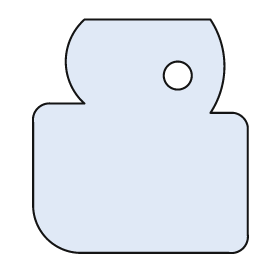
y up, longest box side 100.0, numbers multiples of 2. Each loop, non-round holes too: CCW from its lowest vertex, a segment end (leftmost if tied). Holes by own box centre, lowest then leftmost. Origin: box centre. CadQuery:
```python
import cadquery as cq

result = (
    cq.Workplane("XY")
    .moveTo(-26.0, -50.0)
    .lineTo(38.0, -50.0)
    .threePointArc((44.0, -48.0), (46.0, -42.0))
    .lineTo(46.0, 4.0)
    .threePointArc((44.0, 8.0), (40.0, 10.0))
    .lineTo(30.0, 10.0)
    .threePointArc((36.0, 30.0), (30.0, 50.0))
    .lineTo(-24.0, 50.0)
    .threePointArc((-32.0, 32.0), (-24.0, 14.0))
    .lineTo(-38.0, 14.0)
    .threePointArc((-44.0, 12.0), (-46.0, 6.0))
    .lineTo(-46.0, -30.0)
    .threePointArc((-40.0, -44.0), (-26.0, -50.0))
    .close()
    .moveTo(16.0, 26.0)
    .circle(6.0)
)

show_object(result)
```